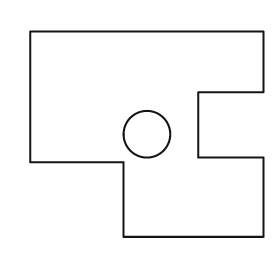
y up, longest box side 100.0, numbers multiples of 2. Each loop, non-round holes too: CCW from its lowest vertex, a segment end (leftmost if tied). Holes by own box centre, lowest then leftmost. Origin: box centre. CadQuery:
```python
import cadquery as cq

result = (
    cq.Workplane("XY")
    .moveTo(-10.0, -44.0)
    .lineTo(50.0, -44.0)
    .lineTo(50.0, -10.0)
    .lineTo(22.0, -10.0)
    .lineTo(22.0, 18.0)
    .lineTo(50.0, 18.0)
    .lineTo(50.0, 44.0)
    .lineTo(-50.0, 44.0)
    .lineTo(-50.0, -12.0)
    .lineTo(-10.0, -12.0)
    .close()
    .moveTo(0.0, 0.0)
    .circle(10.0)
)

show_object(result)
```